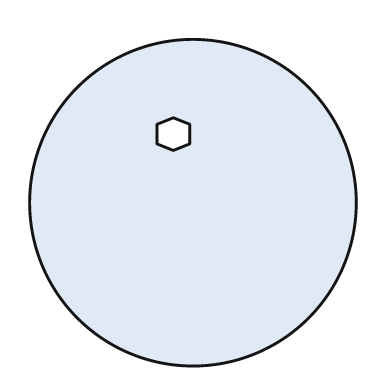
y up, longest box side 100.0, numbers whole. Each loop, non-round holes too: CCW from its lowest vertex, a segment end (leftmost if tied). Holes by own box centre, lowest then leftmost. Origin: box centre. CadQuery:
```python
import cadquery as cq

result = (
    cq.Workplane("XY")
    .moveTo(0.0, 0.0)
    .circle(50.0)
    .moveTo(-6.0, 16.0)
    .lineTo(-1.0, 18.0)
    .lineTo(-1.0, 24.0)
    .lineTo(-6.0, 26.0)
    .lineTo(-11.0, 24.0)
    .lineTo(-11.0, 18.0)
    .close()
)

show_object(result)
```